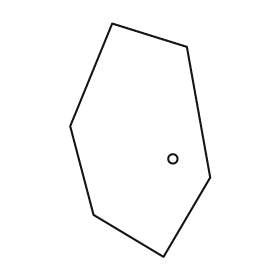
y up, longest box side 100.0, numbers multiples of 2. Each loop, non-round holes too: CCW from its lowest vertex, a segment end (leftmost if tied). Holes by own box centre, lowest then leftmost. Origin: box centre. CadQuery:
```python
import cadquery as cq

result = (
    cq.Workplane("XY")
    .moveTo(10.0, -50.0)
    .lineTo(30.0, -16.0)
    .lineTo(20.0, 40.0)
    .lineTo(-12.0, 50.0)
    .lineTo(-30.0, 6.0)
    .lineTo(-20.0, -32.0)
    .close()
    .moveTo(14.0, -8.0)
    .circle(2.0)
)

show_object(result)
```